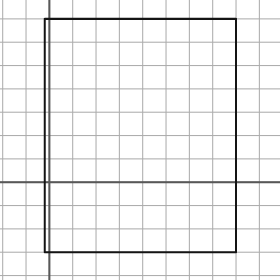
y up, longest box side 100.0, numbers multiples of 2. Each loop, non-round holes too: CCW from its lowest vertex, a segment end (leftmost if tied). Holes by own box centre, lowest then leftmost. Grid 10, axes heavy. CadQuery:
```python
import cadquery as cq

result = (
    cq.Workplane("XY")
    .moveTo(-2.0, -30.0)
    .lineTo(80.0, -30.0)
    .lineTo(80.0, 70.0)
    .lineTo(-2.0, 70.0)
    .close()
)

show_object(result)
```